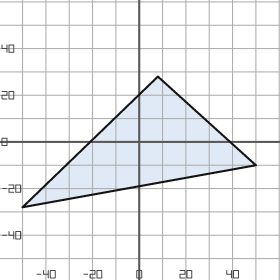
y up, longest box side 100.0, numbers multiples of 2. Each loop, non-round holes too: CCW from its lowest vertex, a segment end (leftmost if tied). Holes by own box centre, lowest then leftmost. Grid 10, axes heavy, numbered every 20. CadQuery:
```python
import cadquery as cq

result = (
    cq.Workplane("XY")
    .moveTo(-50.0, -28.0)
    .lineTo(50.0, -10.0)
    .lineTo(8.0, 28.0)
    .close()
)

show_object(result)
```